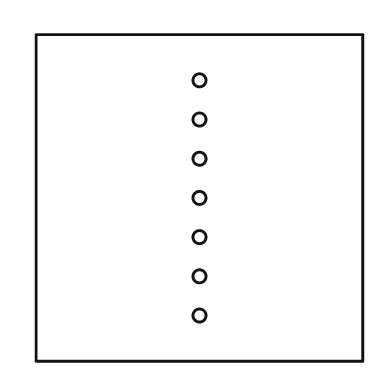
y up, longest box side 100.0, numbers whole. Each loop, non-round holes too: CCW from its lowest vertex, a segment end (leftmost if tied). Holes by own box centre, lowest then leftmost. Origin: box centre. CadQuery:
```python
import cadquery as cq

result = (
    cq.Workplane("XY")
    .moveTo(-50.0, -50.0)
    .lineTo(50.0, -50.0)
    .lineTo(50.0, 50.0)
    .lineTo(-50.0, 50.0)
    .close()
    .moveTo(0.0, -36.0)
    .circle(2.0)
    .moveTo(0.0, -24.0)
    .circle(2.0)
    .moveTo(0.0, -12.0)
    .circle(2.0)
    .moveTo(0.0, 0.0)
    .circle(2.0)
    .moveTo(0.0, 12.0)
    .circle(2.0)
    .moveTo(0.0, 24.0)
    .circle(2.0)
    .moveTo(0.0, 36.0)
    .circle(2.0)
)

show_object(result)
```